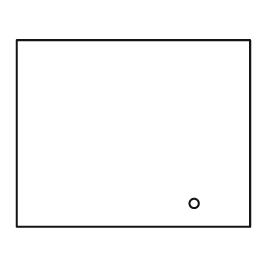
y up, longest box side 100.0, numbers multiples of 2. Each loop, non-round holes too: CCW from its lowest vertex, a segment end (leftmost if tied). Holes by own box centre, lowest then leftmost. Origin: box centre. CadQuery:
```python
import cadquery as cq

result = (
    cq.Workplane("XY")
    .moveTo(-50.0, -40.0)
    .lineTo(50.0, -40.0)
    .lineTo(50.0, 40.0)
    .lineTo(-50.0, 40.0)
    .close()
    .moveTo(26.0, -30.0)
    .circle(2.0)
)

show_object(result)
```